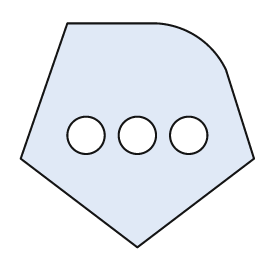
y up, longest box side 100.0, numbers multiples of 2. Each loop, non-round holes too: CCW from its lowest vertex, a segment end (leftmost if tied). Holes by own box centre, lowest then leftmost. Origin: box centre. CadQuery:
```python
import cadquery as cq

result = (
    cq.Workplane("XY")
    .moveTo(0.0, -48.0)
    .lineTo(50.0, -10.0)
    .lineTo(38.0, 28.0)
    .threePointArc((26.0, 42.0), (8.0, 48.0))
    .lineTo(-30.0, 48.0)
    .lineTo(-50.0, -10.0)
    .close()
    .moveTo(-22.0, 0.0)
    .circle(8.0)
    .moveTo(0.0, 0.0)
    .circle(8.0)
    .moveTo(22.0, 0.0)
    .circle(8.0)
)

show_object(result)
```